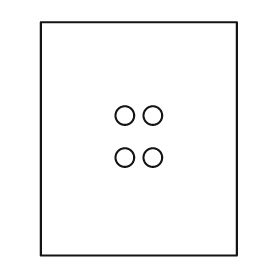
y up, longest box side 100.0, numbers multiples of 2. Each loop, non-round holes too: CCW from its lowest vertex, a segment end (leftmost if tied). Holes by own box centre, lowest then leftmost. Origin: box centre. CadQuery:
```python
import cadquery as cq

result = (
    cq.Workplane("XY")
    .moveTo(-42.0, -50.0)
    .lineTo(42.0, -50.0)
    .lineTo(42.0, 50.0)
    .lineTo(-42.0, 50.0)
    .close()
    .moveTo(-6.0, -8.0)
    .circle(4.0)
    .moveTo(6.0, -8.0)
    .circle(4.0)
    .moveTo(-6.0, 10.0)
    .circle(4.0)
    .moveTo(6.0, 10.0)
    .circle(4.0)
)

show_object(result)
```